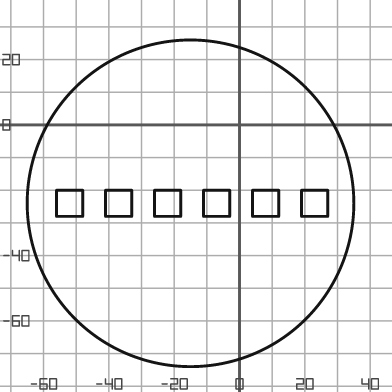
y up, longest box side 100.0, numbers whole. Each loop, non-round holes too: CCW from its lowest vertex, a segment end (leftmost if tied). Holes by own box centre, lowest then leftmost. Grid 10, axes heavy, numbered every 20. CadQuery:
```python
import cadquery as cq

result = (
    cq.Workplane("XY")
    .moveTo(-15.0, -24.0)
    .circle(50.0)
    .moveTo(-56.0, -28.0)
    .lineTo(-48.0, -28.0)
    .lineTo(-48.0, -20.0)
    .lineTo(-56.0, -20.0)
    .close()
    .moveTo(-41.0, -28.0)
    .lineTo(-33.0, -28.0)
    .lineTo(-33.0, -20.0)
    .lineTo(-41.0, -20.0)
    .close()
    .moveTo(-26.0, -28.0)
    .lineTo(-18.0, -28.0)
    .lineTo(-18.0, -20.0)
    .lineTo(-26.0, -20.0)
    .close()
    .moveTo(-11.0, -28.0)
    .lineTo(-3.0, -28.0)
    .lineTo(-3.0, -20.0)
    .lineTo(-11.0, -20.0)
    .close()
    .moveTo(4.0, -28.0)
    .lineTo(12.0, -28.0)
    .lineTo(12.0, -20.0)
    .lineTo(4.0, -20.0)
    .close()
    .moveTo(19.0, -28.0)
    .lineTo(27.0, -28.0)
    .lineTo(27.0, -20.0)
    .lineTo(19.0, -20.0)
    .close()
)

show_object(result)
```